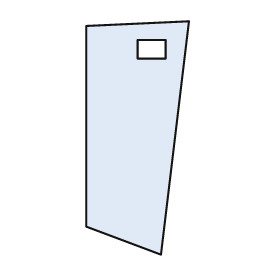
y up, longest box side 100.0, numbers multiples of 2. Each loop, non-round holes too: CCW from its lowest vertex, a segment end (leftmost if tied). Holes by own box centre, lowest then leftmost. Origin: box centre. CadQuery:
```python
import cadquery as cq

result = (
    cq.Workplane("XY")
    .moveTo(10.0, -50.0)
    .lineTo(22.0, 50.0)
    .lineTo(-22.0, 48.0)
    .lineTo(-22.0, -38.0)
    .close()
    .moveTo(0.0, 34.0)
    .lineTo(12.0, 34.0)
    .lineTo(12.0, 42.0)
    .lineTo(0.0, 42.0)
    .close()
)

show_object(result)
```